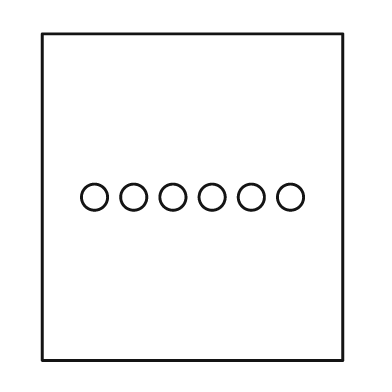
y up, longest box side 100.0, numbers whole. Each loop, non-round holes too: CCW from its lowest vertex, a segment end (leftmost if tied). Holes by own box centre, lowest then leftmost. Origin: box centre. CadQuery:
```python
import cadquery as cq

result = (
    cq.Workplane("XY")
    .moveTo(-46.0, -50.0)
    .lineTo(46.0, -50.0)
    .lineTo(46.0, 50.0)
    .lineTo(-46.0, 50.0)
    .close()
    .moveTo(-30.0, 0.0)
    .circle(4.0)
    .moveTo(-18.0, 0.0)
    .circle(4.0)
    .moveTo(-6.0, 0.0)
    .circle(4.0)
    .moveTo(6.0, 0.0)
    .circle(4.0)
    .moveTo(18.0, 0.0)
    .circle(4.0)
    .moveTo(30.0, 0.0)
    .circle(4.0)
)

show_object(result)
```